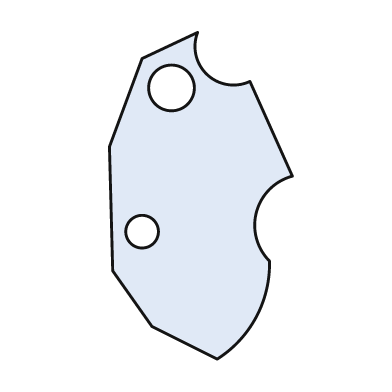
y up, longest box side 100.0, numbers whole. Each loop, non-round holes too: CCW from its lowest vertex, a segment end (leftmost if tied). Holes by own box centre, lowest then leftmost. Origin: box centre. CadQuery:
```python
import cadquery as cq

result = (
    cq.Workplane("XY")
    .moveTo(5.0, -50.0)
    .threePointArc((17.0, -37.0), (21.0, -20.0))
    .threePointArc((17.0, -5.0), (28.0, 6.0))
    .lineTo(15.0, 35.0)
    .threePointArc((2.0, 37.0), (-1.0, 50.0))
    .lineTo(-18.0, 42.0)
    .lineTo(-28.0, 15.0)
    .lineTo(-27.0, -23.0)
    .lineTo(-15.0, -40.0)
    .close()
    .moveTo(-18.0, -11.0)
    .circle(5.0)
    .moveTo(-9.0, 33.0)
    .circle(7.0)
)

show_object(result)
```